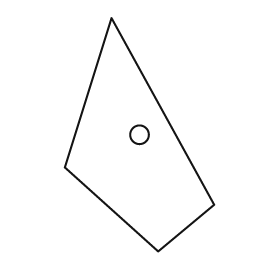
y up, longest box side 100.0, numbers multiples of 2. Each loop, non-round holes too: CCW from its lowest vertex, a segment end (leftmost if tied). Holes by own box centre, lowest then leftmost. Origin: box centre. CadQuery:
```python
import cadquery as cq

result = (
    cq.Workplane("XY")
    .moveTo(8.0, -50.0)
    .lineTo(32.0, -30.0)
    .lineTo(-12.0, 50.0)
    .lineTo(-32.0, -14.0)
    .close()
    .moveTo(0.0, 0.0)
    .circle(4.0)
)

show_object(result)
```